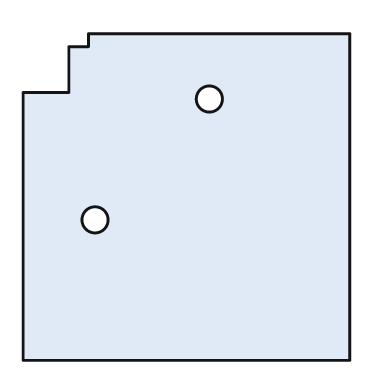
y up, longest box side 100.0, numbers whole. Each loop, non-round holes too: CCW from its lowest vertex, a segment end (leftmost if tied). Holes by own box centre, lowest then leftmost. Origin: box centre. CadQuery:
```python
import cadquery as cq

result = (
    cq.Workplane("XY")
    .moveTo(-50.0, -50.0)
    .lineTo(50.0, -50.0)
    .lineTo(50.0, 50.0)
    .lineTo(-30.0, 50.0)
    .lineTo(-30.0, 46.0)
    .lineTo(-36.0, 46.0)
    .lineTo(-36.0, 32.0)
    .lineTo(-50.0, 32.0)
    .close()
    .moveTo(-28.0, -7.0)
    .circle(4.0)
    .moveTo(7.0, 30.0)
    .circle(4.0)
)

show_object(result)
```